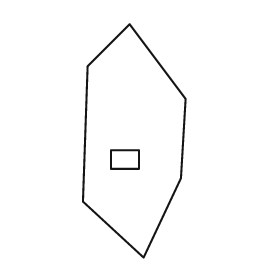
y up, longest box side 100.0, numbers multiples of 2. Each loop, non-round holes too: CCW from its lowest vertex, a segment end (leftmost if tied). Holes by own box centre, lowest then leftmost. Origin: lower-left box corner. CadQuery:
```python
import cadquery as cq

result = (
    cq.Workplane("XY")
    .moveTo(26.0, 0.0)
    .lineTo(42.0, 34.0)
    .lineTo(44.0, 68.0)
    .lineTo(20.0, 100.0)
    .lineTo(2.0, 82.0)
    .lineTo(0.0, 24.0)
    .close()
    .moveTo(12.0, 38.0)
    .lineTo(24.0, 38.0)
    .lineTo(24.0, 46.0)
    .lineTo(12.0, 46.0)
    .close()
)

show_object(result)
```